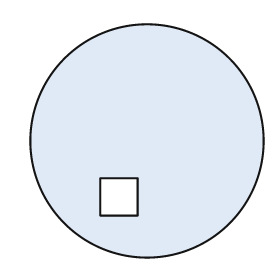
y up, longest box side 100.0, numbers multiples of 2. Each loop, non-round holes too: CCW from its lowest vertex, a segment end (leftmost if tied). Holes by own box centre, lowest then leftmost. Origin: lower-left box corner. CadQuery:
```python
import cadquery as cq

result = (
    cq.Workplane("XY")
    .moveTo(50.0, 50.0)
    .circle(50.0)
    .moveTo(30.0, 18.0)
    .lineTo(46.0, 18.0)
    .lineTo(46.0, 34.0)
    .lineTo(30.0, 34.0)
    .close()
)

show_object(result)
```